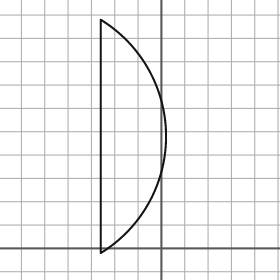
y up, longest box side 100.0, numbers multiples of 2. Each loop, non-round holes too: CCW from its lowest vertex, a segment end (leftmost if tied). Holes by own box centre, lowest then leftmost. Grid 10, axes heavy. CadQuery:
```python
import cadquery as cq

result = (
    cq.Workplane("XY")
    .moveTo(-26.0, -2.0)
    .threePointArc((2.0, 48.0), (-26.0, 98.0))
    .close()
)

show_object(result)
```